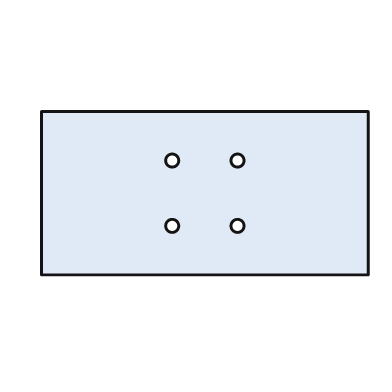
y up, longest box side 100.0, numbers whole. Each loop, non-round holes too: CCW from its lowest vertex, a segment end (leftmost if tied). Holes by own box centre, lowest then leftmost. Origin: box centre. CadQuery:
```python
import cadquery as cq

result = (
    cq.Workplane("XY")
    .moveTo(-50.0, -25.0)
    .lineTo(50.0, -25.0)
    .lineTo(50.0, 25.0)
    .lineTo(-50.0, 25.0)
    .close()
    .moveTo(-10.0, -10.0)
    .circle(2.0)
    .moveTo(10.0, -10.0)
    .circle(2.0)
    .moveTo(-10.0, 10.0)
    .circle(2.0)
    .moveTo(10.0, 10.0)
    .circle(2.0)
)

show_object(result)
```